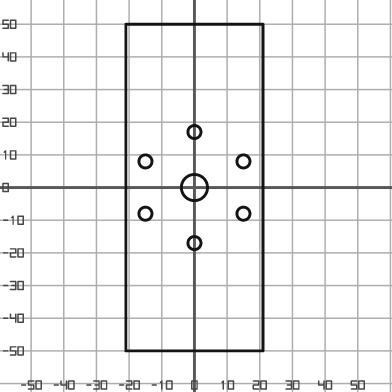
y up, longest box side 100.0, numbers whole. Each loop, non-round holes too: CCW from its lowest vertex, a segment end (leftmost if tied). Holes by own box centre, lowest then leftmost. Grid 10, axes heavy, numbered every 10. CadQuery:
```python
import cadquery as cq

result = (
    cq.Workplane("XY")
    .moveTo(-21.0, -50.0)
    .lineTo(21.0, -50.0)
    .lineTo(21.0, 50.0)
    .lineTo(-21.0, 50.0)
    .close()
    .moveTo(0.0, -17.0)
    .circle(2.0)
    .moveTo(-15.0, -8.0)
    .circle(2.0)
    .moveTo(15.0, -8.0)
    .circle(2.0)
    .moveTo(0.0, 0.0)
    .circle(4.0)
    .moveTo(-15.0, 8.0)
    .circle(2.0)
    .moveTo(15.0, 8.0)
    .circle(2.0)
    .moveTo(0.0, 17.0)
    .circle(2.0)
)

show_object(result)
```